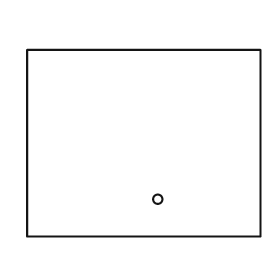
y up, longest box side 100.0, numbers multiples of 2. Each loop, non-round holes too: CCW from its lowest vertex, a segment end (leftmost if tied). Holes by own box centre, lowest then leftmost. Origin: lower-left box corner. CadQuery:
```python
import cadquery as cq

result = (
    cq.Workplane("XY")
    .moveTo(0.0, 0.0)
    .lineTo(100.0, 0.0)
    .lineTo(100.0, 80.0)
    .lineTo(0.0, 80.0)
    .close()
    .moveTo(56.0, 16.0)
    .circle(2.0)
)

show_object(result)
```